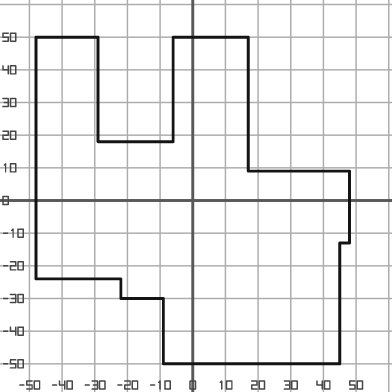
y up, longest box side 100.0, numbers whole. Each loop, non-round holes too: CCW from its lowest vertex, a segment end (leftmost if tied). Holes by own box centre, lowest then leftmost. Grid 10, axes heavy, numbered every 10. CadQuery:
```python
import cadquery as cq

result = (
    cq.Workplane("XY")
    .moveTo(-9.0, -50.0)
    .lineTo(45.0, -50.0)
    .lineTo(45.0, -13.0)
    .lineTo(48.0, -13.0)
    .lineTo(48.0, 9.0)
    .lineTo(17.0, 9.0)
    .lineTo(17.0, 50.0)
    .lineTo(-6.0, 50.0)
    .lineTo(-6.0, 18.0)
    .lineTo(-29.0, 18.0)
    .lineTo(-29.0, 50.0)
    .lineTo(-48.0, 50.0)
    .lineTo(-48.0, -24.0)
    .lineTo(-22.0, -24.0)
    .lineTo(-22.0, -30.0)
    .lineTo(-9.0, -30.0)
    .close()
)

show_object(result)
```